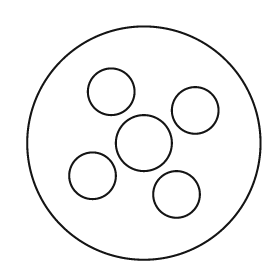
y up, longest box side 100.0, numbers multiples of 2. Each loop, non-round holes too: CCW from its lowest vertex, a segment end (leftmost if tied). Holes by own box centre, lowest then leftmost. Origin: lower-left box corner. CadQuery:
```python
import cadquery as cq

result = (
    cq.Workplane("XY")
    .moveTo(50.0, 50.0)
    .circle(50.0)
    .moveTo(64.0, 28.0)
    .circle(10.0)
    .moveTo(28.0, 36.0)
    .circle(10.0)
    .moveTo(50.0, 50.0)
    .circle(12.0)
    .moveTo(72.0, 64.0)
    .circle(10.0)
    .moveTo(36.0, 72.0)
    .circle(10.0)
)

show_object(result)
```